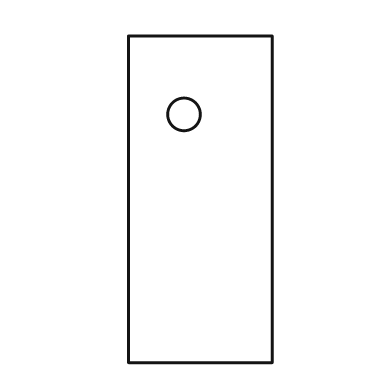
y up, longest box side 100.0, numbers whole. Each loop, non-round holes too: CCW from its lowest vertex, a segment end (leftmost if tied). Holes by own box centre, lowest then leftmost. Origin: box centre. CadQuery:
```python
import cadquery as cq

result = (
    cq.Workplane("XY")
    .moveTo(-22.0, -50.0)
    .lineTo(22.0, -50.0)
    .lineTo(22.0, 50.0)
    .lineTo(-22.0, 50.0)
    .close()
    .moveTo(-5.0, 26.0)
    .circle(5.0)
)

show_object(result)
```